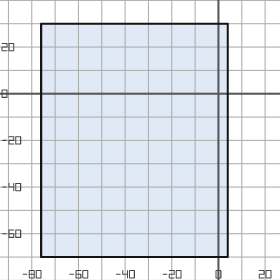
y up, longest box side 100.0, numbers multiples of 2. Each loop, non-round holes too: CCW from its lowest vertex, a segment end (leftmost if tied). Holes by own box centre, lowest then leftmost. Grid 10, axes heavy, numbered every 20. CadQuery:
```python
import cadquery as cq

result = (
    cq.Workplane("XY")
    .moveTo(-76.0, -70.0)
    .lineTo(4.0, -70.0)
    .lineTo(4.0, 30.0)
    .lineTo(-76.0, 30.0)
    .close()
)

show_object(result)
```